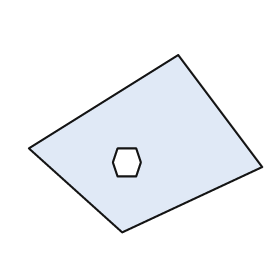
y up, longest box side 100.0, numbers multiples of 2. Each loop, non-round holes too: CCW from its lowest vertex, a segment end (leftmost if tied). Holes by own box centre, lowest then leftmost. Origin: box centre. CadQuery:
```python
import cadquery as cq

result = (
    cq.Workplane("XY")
    .moveTo(-10.0, -38.0)
    .lineTo(50.0, -10.0)
    .lineTo(14.0, 38.0)
    .lineTo(-50.0, -2.0)
    .close()
    .moveTo(-12.0, -14.0)
    .lineTo(-4.0, -14.0)
    .lineTo(-2.0, -8.0)
    .lineTo(-4.0, -2.0)
    .lineTo(-12.0, -2.0)
    .lineTo(-14.0, -8.0)
    .close()
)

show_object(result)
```